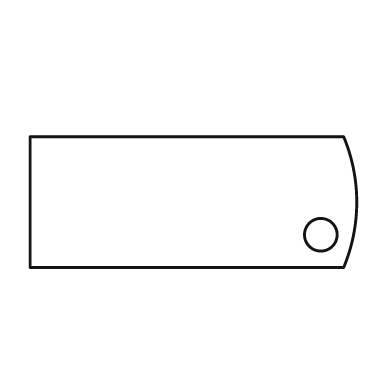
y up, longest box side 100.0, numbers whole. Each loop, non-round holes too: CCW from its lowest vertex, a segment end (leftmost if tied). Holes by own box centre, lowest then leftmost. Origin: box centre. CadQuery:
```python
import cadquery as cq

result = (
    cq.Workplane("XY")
    .moveTo(-50.0, -20.0)
    .lineTo(46.0, -20.0)
    .threePointArc((50.0, 0.0), (46.0, 20.0))
    .lineTo(-50.0, 20.0)
    .close()
    .moveTo(39.0, -10.0)
    .circle(5.0)
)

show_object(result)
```